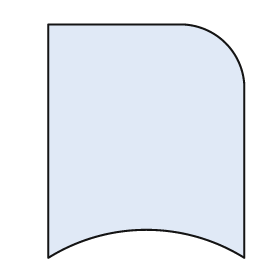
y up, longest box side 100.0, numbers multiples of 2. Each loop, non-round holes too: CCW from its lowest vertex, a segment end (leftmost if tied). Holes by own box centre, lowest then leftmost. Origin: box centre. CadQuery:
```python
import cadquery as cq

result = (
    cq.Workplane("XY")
    .moveTo(-42.0, -50.0)
    .threePointArc((0.0, -38.0), (42.0, -50.0))
    .lineTo(42.0, 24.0)
    .threePointArc((34.0, 42.0), (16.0, 50.0))
    .lineTo(-42.0, 50.0)
    .close()
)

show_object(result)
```